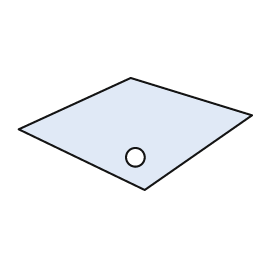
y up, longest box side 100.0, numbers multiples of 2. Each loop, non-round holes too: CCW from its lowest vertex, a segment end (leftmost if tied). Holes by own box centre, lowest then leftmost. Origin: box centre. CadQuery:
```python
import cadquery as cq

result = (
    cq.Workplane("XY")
    .moveTo(4.0, -24.0)
    .lineTo(50.0, 8.0)
    .lineTo(-2.0, 24.0)
    .lineTo(-50.0, 2.0)
    .close()
    .moveTo(0.0, -10.0)
    .circle(4.0)
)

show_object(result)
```